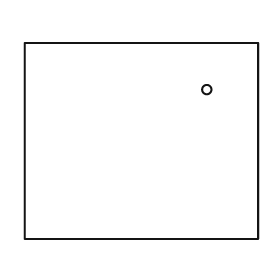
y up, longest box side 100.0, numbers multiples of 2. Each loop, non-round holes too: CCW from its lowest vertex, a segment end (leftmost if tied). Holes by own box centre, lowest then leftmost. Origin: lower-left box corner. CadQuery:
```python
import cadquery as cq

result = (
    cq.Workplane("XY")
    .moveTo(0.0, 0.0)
    .lineTo(100.0, 0.0)
    .lineTo(100.0, 84.0)
    .lineTo(0.0, 84.0)
    .close()
    .moveTo(78.0, 64.0)
    .circle(2.0)
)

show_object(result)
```